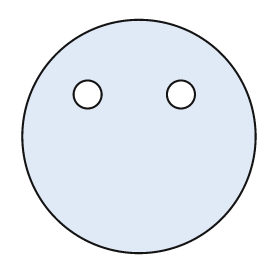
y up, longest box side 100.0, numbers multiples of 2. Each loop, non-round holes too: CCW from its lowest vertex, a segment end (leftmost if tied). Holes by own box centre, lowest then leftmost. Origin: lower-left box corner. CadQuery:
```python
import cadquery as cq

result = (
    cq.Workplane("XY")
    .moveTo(50.0, 50.0)
    .circle(50.0)
    .moveTo(28.0, 68.0)
    .circle(6.0)
    .moveTo(68.0, 68.0)
    .circle(6.0)
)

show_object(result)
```